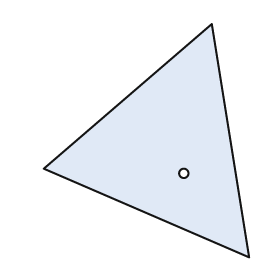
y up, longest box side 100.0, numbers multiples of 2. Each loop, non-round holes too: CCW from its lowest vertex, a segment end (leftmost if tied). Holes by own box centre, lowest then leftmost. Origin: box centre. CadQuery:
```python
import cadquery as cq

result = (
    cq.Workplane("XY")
    .moveTo(44.0, -50.0)
    .lineTo(28.0, 50.0)
    .lineTo(-44.0, -12.0)
    .close()
    .moveTo(16.0, -14.0)
    .circle(2.0)
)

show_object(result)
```